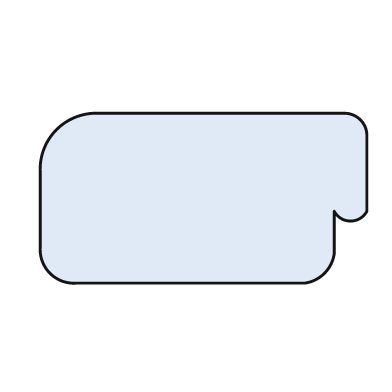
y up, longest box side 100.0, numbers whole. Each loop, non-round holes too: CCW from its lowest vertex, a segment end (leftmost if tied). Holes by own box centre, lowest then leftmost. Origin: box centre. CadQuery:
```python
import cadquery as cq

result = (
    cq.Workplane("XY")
    .moveTo(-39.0, -26.0)
    .lineTo(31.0, -26.0)
    .threePointArc((37.0, -23.0), (40.0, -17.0))
    .lineTo(40.0, -4.0)
    .threePointArc((45.0, -7.0), (50.0, -4.0))
    .lineTo(50.0, 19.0)
    .threePointArc((48.0, 24.0), (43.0, 26.0))
    .lineTo(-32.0, 26.0)
    .threePointArc((-45.0, 21.0), (-50.0, 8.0))
    .lineTo(-50.0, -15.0)
    .threePointArc((-47.0, -23.0), (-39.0, -26.0))
    .close()
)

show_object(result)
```